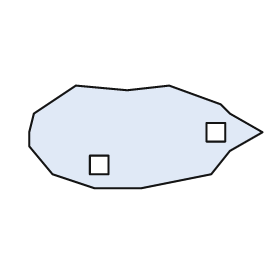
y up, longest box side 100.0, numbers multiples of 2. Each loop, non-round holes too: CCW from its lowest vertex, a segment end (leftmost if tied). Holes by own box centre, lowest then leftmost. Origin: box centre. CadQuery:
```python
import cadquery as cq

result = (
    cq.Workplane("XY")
    .moveTo(-22.0, -22.0)
    .lineTo(-2.0, -22.0)
    .lineTo(28.0, -16.0)
    .lineTo(36.0, -6.0)
    .lineTo(50.0, 2.0)
    .lineTo(36.0, 10.0)
    .lineTo(32.0, 14.0)
    .lineTo(10.0, 22.0)
    .lineTo(-8.0, 20.0)
    .lineTo(-30.0, 22.0)
    .lineTo(-48.0, 10.0)
    .lineTo(-50.0, 2.0)
    .lineTo(-50.0, -4.0)
    .lineTo(-40.0, -16.0)
    .close()
    .moveTo(-24.0, -16.0)
    .lineTo(-16.0, -16.0)
    .lineTo(-16.0, -8.0)
    .lineTo(-24.0, -8.0)
    .close()
    .moveTo(26.0, -2.0)
    .lineTo(34.0, -2.0)
    .lineTo(34.0, 6.0)
    .lineTo(26.0, 6.0)
    .close()
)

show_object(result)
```